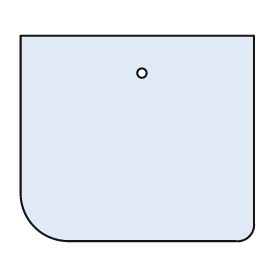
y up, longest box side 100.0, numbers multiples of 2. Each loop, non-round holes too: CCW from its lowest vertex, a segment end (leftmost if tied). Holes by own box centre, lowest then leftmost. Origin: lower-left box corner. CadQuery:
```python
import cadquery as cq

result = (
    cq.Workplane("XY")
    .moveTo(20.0, 0.0)
    .lineTo(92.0, 0.0)
    .threePointArc((98.0, 2.0), (100.0, 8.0))
    .lineTo(100.0, 88.0)
    .lineTo(0.0, 88.0)
    .lineTo(0.0, 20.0)
    .threePointArc((6.0, 6.0), (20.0, 0.0))
    .close()
    .moveTo(52.0, 72.0)
    .circle(2.0)
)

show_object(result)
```